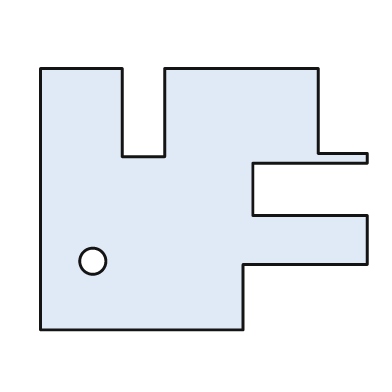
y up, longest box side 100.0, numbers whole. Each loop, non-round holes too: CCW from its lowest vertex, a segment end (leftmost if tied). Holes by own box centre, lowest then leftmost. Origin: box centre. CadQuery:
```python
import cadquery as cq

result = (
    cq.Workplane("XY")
    .moveTo(-50.0, -40.0)
    .lineTo(12.0, -40.0)
    .lineTo(12.0, -20.0)
    .lineTo(50.0, -20.0)
    .lineTo(50.0, -5.0)
    .lineTo(15.0, -5.0)
    .lineTo(15.0, 11.0)
    .lineTo(50.0, 11.0)
    .lineTo(50.0, 14.0)
    .lineTo(35.0, 14.0)
    .lineTo(35.0, 40.0)
    .lineTo(-12.0, 40.0)
    .lineTo(-12.0, 13.0)
    .lineTo(-25.0, 13.0)
    .lineTo(-25.0, 40.0)
    .lineTo(-50.0, 40.0)
    .close()
    .moveTo(-34.0, -19.0)
    .circle(4.0)
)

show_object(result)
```